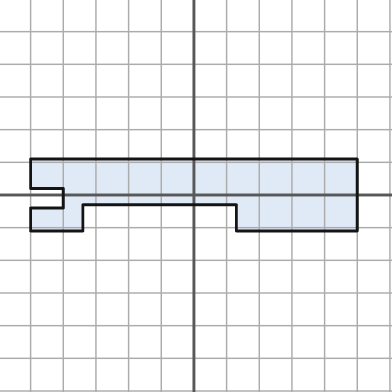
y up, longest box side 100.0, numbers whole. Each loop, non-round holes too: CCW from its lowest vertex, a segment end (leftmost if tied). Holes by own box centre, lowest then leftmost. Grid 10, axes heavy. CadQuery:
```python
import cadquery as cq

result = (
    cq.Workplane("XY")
    .moveTo(-50.0, -11.0)
    .lineTo(-34.0, -11.0)
    .lineTo(-34.0, -3.0)
    .lineTo(13.0, -3.0)
    .lineTo(13.0, -11.0)
    .lineTo(50.0, -11.0)
    .lineTo(50.0, 11.0)
    .lineTo(-50.0, 11.0)
    .lineTo(-50.0, 2.0)
    .lineTo(-40.0, 2.0)
    .lineTo(-40.0, -4.0)
    .lineTo(-50.0, -4.0)
    .close()
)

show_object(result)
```